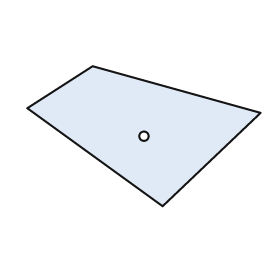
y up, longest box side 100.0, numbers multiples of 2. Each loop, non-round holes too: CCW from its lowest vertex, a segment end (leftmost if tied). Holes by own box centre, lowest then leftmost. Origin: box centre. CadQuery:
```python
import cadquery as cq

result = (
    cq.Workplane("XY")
    .moveTo(8.0, -30.0)
    .lineTo(50.0, 10.0)
    .lineTo(-22.0, 30.0)
    .lineTo(-50.0, 12.0)
    .close()
    .moveTo(0.0, 0.0)
    .circle(2.0)
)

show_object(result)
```